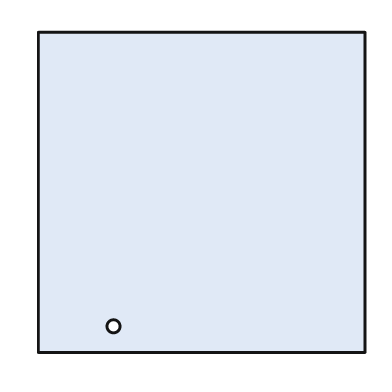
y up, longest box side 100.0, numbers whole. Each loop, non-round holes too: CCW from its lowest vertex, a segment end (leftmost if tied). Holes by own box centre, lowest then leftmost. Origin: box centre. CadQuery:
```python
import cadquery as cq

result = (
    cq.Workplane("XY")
    .moveTo(-50.0, -49.0)
    .lineTo(50.0, -49.0)
    .lineTo(50.0, 49.0)
    .lineTo(-50.0, 49.0)
    .close()
    .moveTo(-27.0, -41.0)
    .circle(2.0)
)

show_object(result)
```